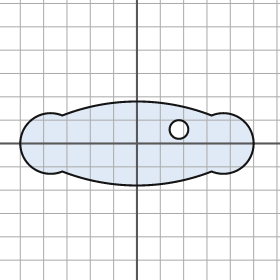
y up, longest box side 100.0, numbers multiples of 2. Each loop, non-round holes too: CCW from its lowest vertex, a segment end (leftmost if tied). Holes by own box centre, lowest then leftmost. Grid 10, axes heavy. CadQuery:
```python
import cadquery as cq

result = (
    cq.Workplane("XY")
    .moveTo(-32.0, -12.0)
    .threePointArc((0.0, -18.0), (32.0, -12.0))
    .threePointArc((50.0, 0.0), (32.0, 12.0))
    .threePointArc((0.0, 18.0), (-32.0, 12.0))
    .threePointArc((-50.0, 0.0), (-32.0, -12.0))
    .close()
    .moveTo(18.0, 6.0)
    .circle(4.0)
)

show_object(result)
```